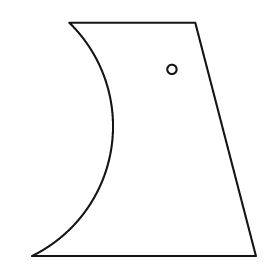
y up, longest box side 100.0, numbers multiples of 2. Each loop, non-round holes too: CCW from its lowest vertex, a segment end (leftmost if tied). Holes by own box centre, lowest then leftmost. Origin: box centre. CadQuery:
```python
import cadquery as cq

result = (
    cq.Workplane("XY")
    .moveTo(-48.0, -50.0)
    .lineTo(48.0, -50.0)
    .lineTo(22.0, 50.0)
    .lineTo(-32.0, 50.0)
    .threePointArc((-14.0, -4.0), (-48.0, -50.0))
    .close()
    .moveTo(12.0, 30.0)
    .circle(2.0)
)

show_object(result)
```